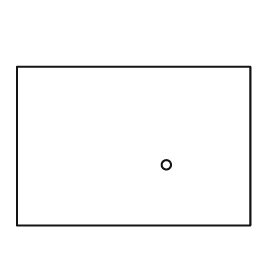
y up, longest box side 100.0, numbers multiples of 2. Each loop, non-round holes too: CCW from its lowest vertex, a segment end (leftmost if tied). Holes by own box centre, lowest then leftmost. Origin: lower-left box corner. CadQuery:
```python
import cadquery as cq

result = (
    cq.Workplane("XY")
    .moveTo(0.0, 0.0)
    .lineTo(100.0, 0.0)
    .lineTo(100.0, 68.0)
    .lineTo(0.0, 68.0)
    .close()
    .moveTo(64.0, 26.0)
    .circle(2.0)
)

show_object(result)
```